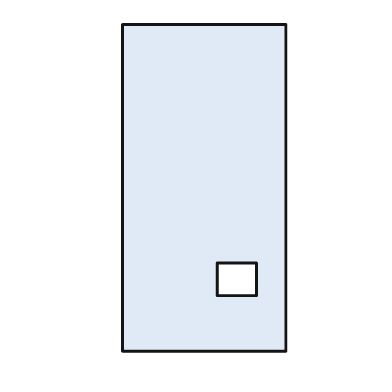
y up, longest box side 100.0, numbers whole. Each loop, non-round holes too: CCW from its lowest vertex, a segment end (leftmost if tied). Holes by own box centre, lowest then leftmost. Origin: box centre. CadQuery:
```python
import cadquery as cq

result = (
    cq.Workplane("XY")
    .moveTo(-25.0, -50.0)
    .lineTo(25.0, -50.0)
    .lineTo(25.0, 50.0)
    .lineTo(-25.0, 50.0)
    .close()
    .moveTo(4.0, -33.0)
    .lineTo(16.0, -33.0)
    .lineTo(16.0, -23.0)
    .lineTo(4.0, -23.0)
    .close()
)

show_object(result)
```